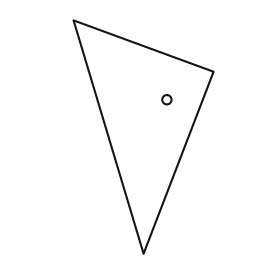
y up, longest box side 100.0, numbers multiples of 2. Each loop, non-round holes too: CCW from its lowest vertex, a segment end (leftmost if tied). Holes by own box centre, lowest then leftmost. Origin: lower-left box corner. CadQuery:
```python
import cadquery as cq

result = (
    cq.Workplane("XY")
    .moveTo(30.0, 0.0)
    .lineTo(60.0, 78.0)
    .lineTo(0.0, 100.0)
    .close()
    .moveTo(40.0, 66.0)
    .circle(2.0)
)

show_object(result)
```